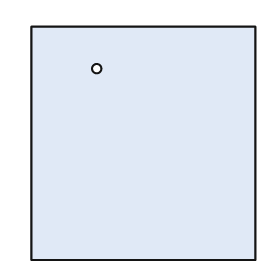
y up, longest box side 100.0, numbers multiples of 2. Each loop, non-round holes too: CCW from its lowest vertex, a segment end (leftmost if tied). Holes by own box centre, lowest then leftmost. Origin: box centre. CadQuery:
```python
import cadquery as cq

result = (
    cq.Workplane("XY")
    .moveTo(-48.0, -50.0)
    .lineTo(48.0, -50.0)
    .lineTo(48.0, 50.0)
    .lineTo(-48.0, 50.0)
    .close()
    .moveTo(-20.0, 32.0)
    .circle(2.0)
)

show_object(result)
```